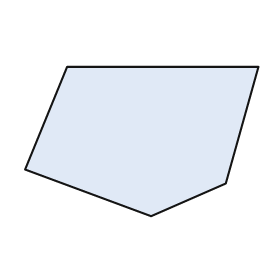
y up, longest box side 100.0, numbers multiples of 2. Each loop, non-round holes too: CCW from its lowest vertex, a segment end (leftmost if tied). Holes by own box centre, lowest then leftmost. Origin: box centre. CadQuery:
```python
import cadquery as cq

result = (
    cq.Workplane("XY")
    .moveTo(4.0, -32.0)
    .lineTo(36.0, -18.0)
    .lineTo(50.0, 32.0)
    .lineTo(-32.0, 32.0)
    .lineTo(-50.0, -12.0)
    .close()
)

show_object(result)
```